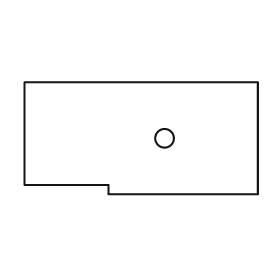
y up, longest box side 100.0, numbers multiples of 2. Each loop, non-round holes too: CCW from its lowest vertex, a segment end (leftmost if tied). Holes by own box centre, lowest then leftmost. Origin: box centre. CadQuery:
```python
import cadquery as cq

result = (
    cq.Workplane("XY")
    .moveTo(-14.0, -24.0)
    .lineTo(50.0, -24.0)
    .lineTo(50.0, 24.0)
    .lineTo(-50.0, 24.0)
    .lineTo(-50.0, -20.0)
    .lineTo(-14.0, -20.0)
    .close()
    .moveTo(10.0, 0.0)
    .circle(4.0)
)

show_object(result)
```